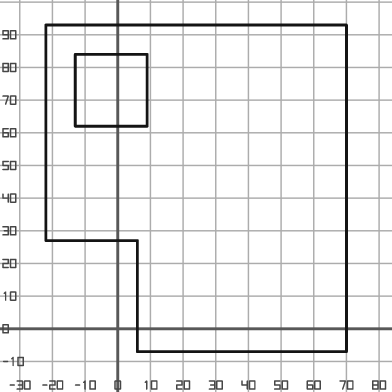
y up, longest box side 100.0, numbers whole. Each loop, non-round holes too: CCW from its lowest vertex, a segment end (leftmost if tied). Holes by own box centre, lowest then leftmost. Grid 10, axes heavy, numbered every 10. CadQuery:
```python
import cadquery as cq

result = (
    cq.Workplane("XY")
    .moveTo(6.0, -7.0)
    .lineTo(70.0, -7.0)
    .lineTo(70.0, 93.0)
    .lineTo(-22.0, 93.0)
    .lineTo(-22.0, 27.0)
    .lineTo(6.0, 27.0)
    .close()
    .moveTo(-13.0, 62.0)
    .lineTo(9.0, 62.0)
    .lineTo(9.0, 84.0)
    .lineTo(-13.0, 84.0)
    .close()
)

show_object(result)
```